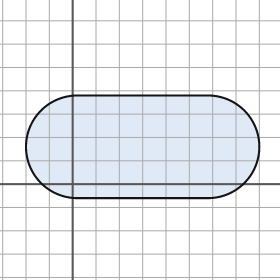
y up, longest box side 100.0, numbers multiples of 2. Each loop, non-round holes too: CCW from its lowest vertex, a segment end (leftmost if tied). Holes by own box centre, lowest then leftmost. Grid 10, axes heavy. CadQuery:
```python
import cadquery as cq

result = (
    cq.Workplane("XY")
    .moveTo(2.0, -6.0)
    .lineTo(58.0, -6.0)
    .threePointArc((80.0, 16.0), (58.0, 38.0))
    .lineTo(2.0, 38.0)
    .threePointArc((-20.0, 16.0), (2.0, -6.0))
    .close()
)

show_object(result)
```